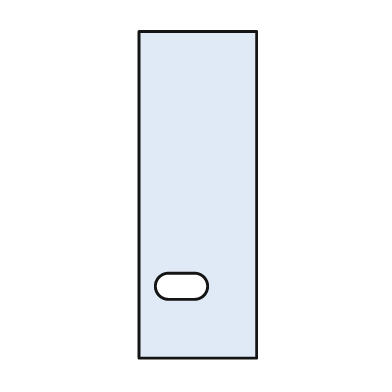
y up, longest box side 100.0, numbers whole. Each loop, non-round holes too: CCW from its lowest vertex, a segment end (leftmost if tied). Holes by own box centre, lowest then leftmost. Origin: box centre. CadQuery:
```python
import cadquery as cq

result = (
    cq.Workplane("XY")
    .moveTo(-18.0, -50.0)
    .lineTo(18.0, -50.0)
    .lineTo(18.0, 50.0)
    .lineTo(-18.0, 50.0)
    .close()
    .moveTo(-9.0, -32.0)
    .lineTo(-1.0, -32.0)
    .threePointArc((3.0, -28.0), (-1.0, -24.0))
    .lineTo(-9.0, -24.0)
    .threePointArc((-13.0, -28.0), (-9.0, -32.0))
    .close()
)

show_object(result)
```